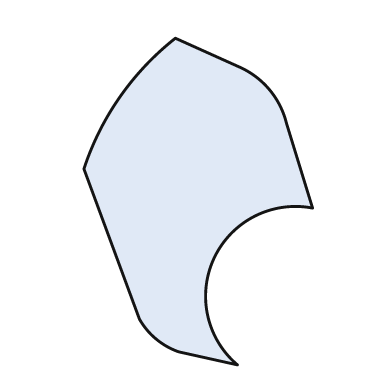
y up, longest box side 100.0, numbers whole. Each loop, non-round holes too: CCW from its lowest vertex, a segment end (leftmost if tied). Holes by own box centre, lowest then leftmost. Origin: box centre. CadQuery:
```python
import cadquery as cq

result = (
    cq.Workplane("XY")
    .moveTo(12.0, -50.0)
    .threePointArc((5.0, -17.0), (35.0, -2.0))
    .lineTo(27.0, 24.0)
    .threePointArc((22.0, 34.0), (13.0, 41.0))
    .lineTo(-7.0, 50.0)
    .threePointArc((-24.0, 32.0), (-35.0, 10.0))
    .lineTo(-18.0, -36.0)
    .threePointArc((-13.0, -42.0), (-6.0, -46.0))
    .close()
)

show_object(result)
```